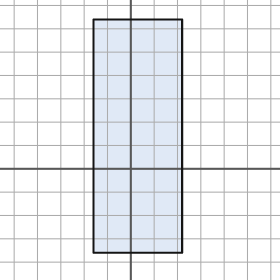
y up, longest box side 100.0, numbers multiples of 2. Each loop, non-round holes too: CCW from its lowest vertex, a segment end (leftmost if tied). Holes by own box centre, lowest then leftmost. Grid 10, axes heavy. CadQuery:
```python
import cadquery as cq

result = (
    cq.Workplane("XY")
    .moveTo(-16.0, -36.0)
    .lineTo(22.0, -36.0)
    .lineTo(22.0, 64.0)
    .lineTo(-16.0, 64.0)
    .close()
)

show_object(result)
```